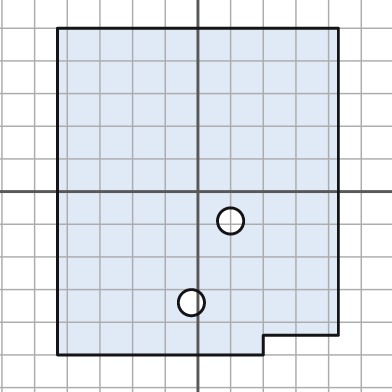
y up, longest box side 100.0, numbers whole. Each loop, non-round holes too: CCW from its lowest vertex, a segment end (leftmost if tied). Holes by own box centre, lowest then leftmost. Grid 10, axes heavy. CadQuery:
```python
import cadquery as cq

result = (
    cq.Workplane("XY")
    .moveTo(-43.0, -50.0)
    .lineTo(20.0, -50.0)
    .lineTo(20.0, -44.0)
    .lineTo(43.0, -44.0)
    .lineTo(43.0, 50.0)
    .lineTo(-43.0, 50.0)
    .close()
    .moveTo(-2.0, -34.0)
    .circle(4.0)
    .moveTo(10.0, -9.0)
    .circle(4.0)
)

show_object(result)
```